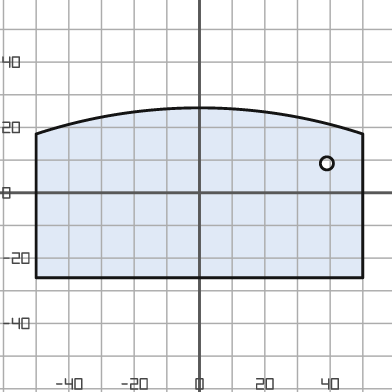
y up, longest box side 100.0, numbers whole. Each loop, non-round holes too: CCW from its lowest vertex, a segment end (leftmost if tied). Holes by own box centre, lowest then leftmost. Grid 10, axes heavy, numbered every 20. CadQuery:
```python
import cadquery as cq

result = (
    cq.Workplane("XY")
    .moveTo(-50.0, -26.0)
    .lineTo(50.0, -26.0)
    .lineTo(50.0, 18.0)
    .threePointArc((0.0, 26.0), (-50.0, 18.0))
    .close()
    .moveTo(39.0, 9.0)
    .circle(2.0)
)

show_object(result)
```